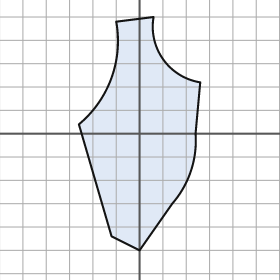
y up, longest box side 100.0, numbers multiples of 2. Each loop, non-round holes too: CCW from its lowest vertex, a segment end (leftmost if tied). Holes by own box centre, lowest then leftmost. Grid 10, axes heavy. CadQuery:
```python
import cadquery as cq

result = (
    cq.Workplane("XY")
    .moveTo(0.0, -50.0)
    .lineTo(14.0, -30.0)
    .threePointArc((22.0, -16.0), (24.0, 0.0))
    .lineTo(26.0, 22.0)
    .threePointArc((10.0, 32.0), (6.0, 50.0))
    .lineTo(-10.0, 48.0)
    .threePointArc((-12.0, 24.0), (-26.0, 4.0))
    .lineTo(-12.0, -44.0)
    .close()
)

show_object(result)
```